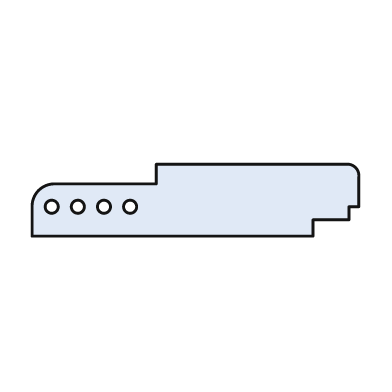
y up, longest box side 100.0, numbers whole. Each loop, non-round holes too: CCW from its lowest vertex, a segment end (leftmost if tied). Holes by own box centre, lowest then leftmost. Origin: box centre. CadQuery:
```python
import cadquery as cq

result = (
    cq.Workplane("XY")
    .moveTo(-50.0, -11.0)
    .lineTo(36.0, -11.0)
    .lineTo(36.0, -6.0)
    .lineTo(47.0, -6.0)
    .lineTo(47.0, -2.0)
    .lineTo(50.0, -2.0)
    .lineTo(50.0, 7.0)
    .threePointArc((49.0, 10.0), (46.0, 11.0))
    .lineTo(-12.0, 11.0)
    .lineTo(-12.0, 5.0)
    .lineTo(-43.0, 5.0)
    .threePointArc((-48.0, 3.0), (-50.0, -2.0))
    .close()
    .moveTo(-44.0, -2.0)
    .circle(2.0)
    .moveTo(-36.0, -2.0)
    .circle(2.0)
    .moveTo(-28.0, -2.0)
    .circle(2.0)
    .moveTo(-20.0, -2.0)
    .circle(2.0)
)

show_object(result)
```